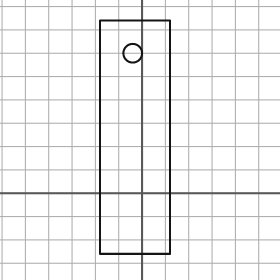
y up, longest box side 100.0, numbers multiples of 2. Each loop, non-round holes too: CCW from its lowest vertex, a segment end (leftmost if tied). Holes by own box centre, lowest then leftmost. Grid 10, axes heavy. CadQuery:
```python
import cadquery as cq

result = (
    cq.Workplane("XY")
    .moveTo(-18.0, -26.0)
    .lineTo(12.0, -26.0)
    .lineTo(12.0, 74.0)
    .lineTo(-18.0, 74.0)
    .close()
    .moveTo(-4.0, 60.0)
    .circle(4.0)
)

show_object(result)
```